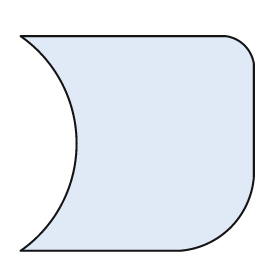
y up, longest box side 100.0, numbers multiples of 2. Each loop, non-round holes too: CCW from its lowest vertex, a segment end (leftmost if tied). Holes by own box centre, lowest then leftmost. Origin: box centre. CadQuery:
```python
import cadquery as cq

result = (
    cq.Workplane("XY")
    .moveTo(-50.0, -46.0)
    .lineTo(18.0, -46.0)
    .threePointArc((40.0, -36.0), (50.0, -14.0))
    .lineTo(50.0, 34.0)
    .threePointArc((46.0, 42.0), (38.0, 46.0))
    .lineTo(-50.0, 46.0)
    .threePointArc((-26.0, 0.0), (-50.0, -46.0))
    .close()
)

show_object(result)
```